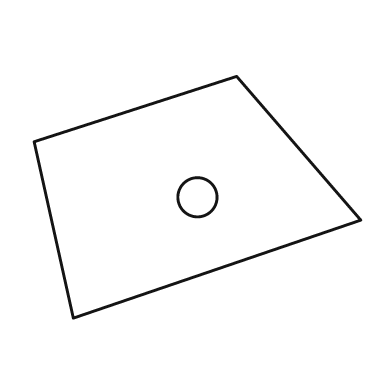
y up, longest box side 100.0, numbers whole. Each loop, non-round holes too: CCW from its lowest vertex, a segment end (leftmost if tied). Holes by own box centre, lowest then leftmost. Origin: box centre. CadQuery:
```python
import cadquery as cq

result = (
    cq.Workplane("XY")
    .moveTo(-38.0, -37.0)
    .lineTo(50.0, -7.0)
    .lineTo(12.0, 37.0)
    .lineTo(-50.0, 17.0)
    .close()
    .moveTo(0.0, 0.0)
    .circle(6.0)
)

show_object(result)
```